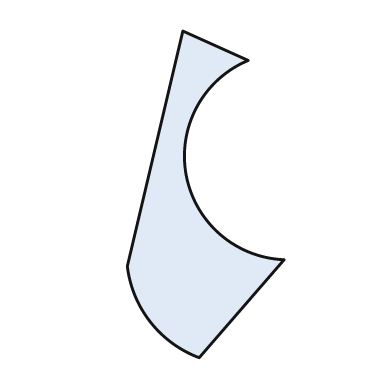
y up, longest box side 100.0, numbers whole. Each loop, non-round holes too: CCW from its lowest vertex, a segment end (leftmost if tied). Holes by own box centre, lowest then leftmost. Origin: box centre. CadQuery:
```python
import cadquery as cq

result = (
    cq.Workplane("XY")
    .moveTo(-2.0, -50.0)
    .lineTo(24.0, -20.0)
    .threePointArc((-6.0, 6.0), (13.0, 41.0))
    .lineTo(-7.0, 50.0)
    .lineTo(-24.0, -22.0)
    .threePointArc((-17.0, -39.0), (-2.0, -50.0))
    .close()
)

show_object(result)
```